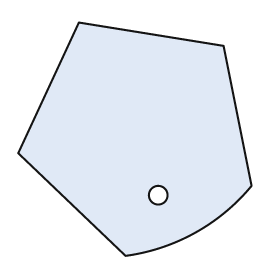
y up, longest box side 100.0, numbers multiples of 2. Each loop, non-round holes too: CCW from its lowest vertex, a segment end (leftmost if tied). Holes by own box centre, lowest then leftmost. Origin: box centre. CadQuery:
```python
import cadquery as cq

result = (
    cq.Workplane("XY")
    .moveTo(-4.0, -50.0)
    .threePointArc((26.0, -40.0), (50.0, -20.0))
    .lineTo(38.0, 40.0)
    .lineTo(-24.0, 50.0)
    .lineTo(-50.0, -6.0)
    .close()
    .moveTo(10.0, -24.0)
    .circle(4.0)
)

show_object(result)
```